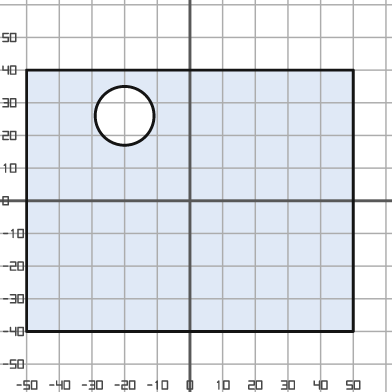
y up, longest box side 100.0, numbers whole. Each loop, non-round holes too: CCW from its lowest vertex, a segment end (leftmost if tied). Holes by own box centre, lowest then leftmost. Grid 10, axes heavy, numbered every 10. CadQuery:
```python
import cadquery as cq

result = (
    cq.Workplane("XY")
    .moveTo(-50.0, -40.0)
    .lineTo(50.0, -40.0)
    .lineTo(50.0, 40.0)
    .lineTo(-50.0, 40.0)
    .close()
    .moveTo(-20.0, 26.0)
    .circle(9.0)
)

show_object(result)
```